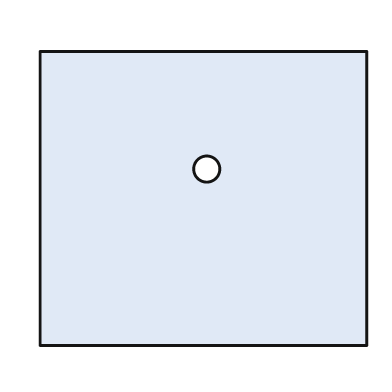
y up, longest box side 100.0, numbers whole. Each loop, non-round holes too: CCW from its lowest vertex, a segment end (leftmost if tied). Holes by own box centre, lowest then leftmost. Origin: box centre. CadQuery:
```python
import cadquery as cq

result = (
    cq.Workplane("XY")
    .moveTo(-50.0, -45.0)
    .lineTo(50.0, -45.0)
    .lineTo(50.0, 45.0)
    .lineTo(-50.0, 45.0)
    .close()
    .moveTo(1.0, 9.0)
    .circle(4.0)
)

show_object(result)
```